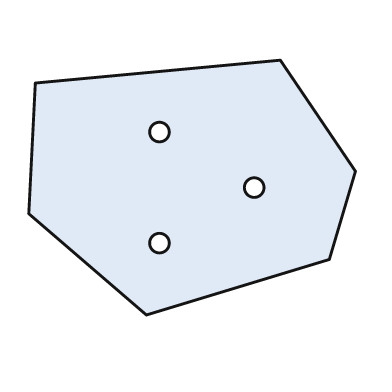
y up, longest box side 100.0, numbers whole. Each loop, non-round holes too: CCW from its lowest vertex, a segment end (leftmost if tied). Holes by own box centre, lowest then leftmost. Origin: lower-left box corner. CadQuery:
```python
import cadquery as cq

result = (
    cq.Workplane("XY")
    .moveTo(36.0, 0.0)
    .lineTo(92.0, 17.0)
    .lineTo(100.0, 44.0)
    .lineTo(77.0, 78.0)
    .lineTo(2.0, 71.0)
    .lineTo(0.0, 31.0)
    .close()
    .moveTo(40.0, 22.0)
    .circle(3.0)
    .moveTo(69.0, 39.0)
    .circle(3.0)
    .moveTo(40.0, 56.0)
    .circle(3.0)
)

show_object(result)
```